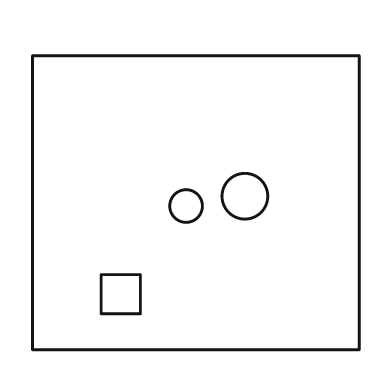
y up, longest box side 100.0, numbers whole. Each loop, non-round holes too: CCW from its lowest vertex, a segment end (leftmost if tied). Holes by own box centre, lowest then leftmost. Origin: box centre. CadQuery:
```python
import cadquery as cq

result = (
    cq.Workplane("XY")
    .moveTo(-50.0, -45.0)
    .lineTo(50.0, -45.0)
    .lineTo(50.0, 45.0)
    .lineTo(-50.0, 45.0)
    .close()
    .moveTo(-29.0, -34.0)
    .lineTo(-17.0, -34.0)
    .lineTo(-17.0, -22.0)
    .lineTo(-29.0, -22.0)
    .close()
    .moveTo(-3.0, -1.0)
    .circle(5.0)
    .moveTo(15.0, 2.0)
    .circle(7.0)
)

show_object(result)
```